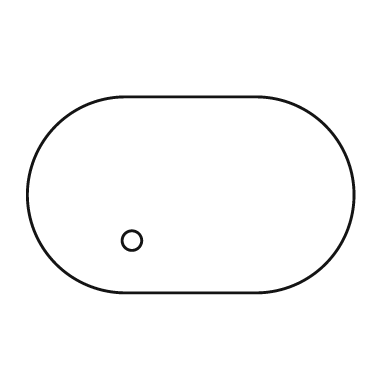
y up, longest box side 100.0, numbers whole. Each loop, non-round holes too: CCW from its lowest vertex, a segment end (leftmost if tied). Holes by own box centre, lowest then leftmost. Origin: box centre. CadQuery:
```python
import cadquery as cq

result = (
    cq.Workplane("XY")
    .moveTo(-20.0, -30.0)
    .lineTo(20.0, -30.0)
    .threePointArc((50.0, 0.0), (20.0, 30.0))
    .lineTo(-20.0, 30.0)
    .threePointArc((-50.0, 0.0), (-20.0, -30.0))
    .close()
    .moveTo(-18.0, -14.0)
    .circle(3.0)
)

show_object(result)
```